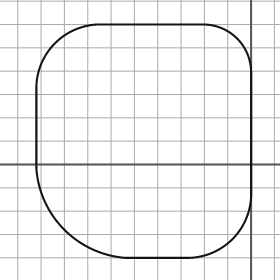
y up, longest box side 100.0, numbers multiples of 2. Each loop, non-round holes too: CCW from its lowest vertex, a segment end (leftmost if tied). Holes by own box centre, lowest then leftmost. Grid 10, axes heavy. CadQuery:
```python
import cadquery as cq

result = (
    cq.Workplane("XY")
    .moveTo(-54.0, -40.0)
    .lineTo(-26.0, -40.0)
    .threePointArc((-8.0, -32.0), (0.0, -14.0))
    .lineTo(0.0, 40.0)
    .threePointArc((-6.0, 54.0), (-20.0, 60.0))
    .lineTo(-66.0, 60.0)
    .threePointArc((-84.0, 52.0), (-92.0, 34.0))
    .lineTo(-92.0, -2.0)
    .threePointArc((-80.0, -28.0), (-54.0, -40.0))
    .close()
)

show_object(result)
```